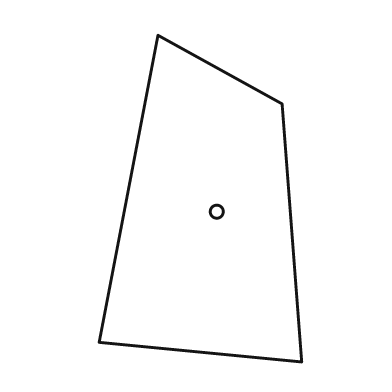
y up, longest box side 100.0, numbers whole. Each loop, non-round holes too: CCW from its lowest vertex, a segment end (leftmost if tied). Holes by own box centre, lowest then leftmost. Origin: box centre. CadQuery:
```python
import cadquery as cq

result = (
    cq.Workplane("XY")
    .moveTo(31.0, -50.0)
    .lineTo(25.0, 29.0)
    .lineTo(-13.0, 50.0)
    .lineTo(-31.0, -44.0)
    .close()
    .moveTo(5.0, -4.0)
    .circle(2.0)
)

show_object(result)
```